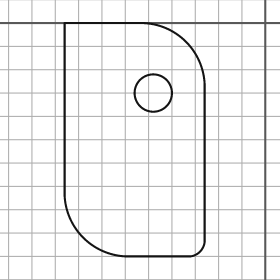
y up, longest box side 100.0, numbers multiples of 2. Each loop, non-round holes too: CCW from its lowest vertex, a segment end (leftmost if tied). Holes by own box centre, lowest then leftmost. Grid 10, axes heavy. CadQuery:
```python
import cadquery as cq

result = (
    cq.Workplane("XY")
    .moveTo(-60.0, -100.0)
    .lineTo(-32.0, -100.0)
    .threePointArc((-28.0, -98.0), (-26.0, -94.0))
    .lineTo(-26.0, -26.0)
    .threePointArc((-34.0, -8.0), (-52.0, 0.0))
    .lineTo(-86.0, 0.0)
    .lineTo(-86.0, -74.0)
    .threePointArc((-78.0, -92.0), (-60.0, -100.0))
    .close()
    .moveTo(-48.0, -30.0)
    .circle(8.0)
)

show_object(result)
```